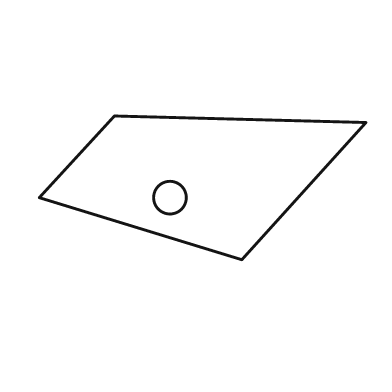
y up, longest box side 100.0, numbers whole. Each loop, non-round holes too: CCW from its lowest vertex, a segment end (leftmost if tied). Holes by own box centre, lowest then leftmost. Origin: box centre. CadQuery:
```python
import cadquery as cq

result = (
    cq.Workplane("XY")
    .moveTo(12.0, -22.0)
    .lineTo(50.0, 20.0)
    .lineTo(-27.0, 22.0)
    .lineTo(-50.0, -3.0)
    .close()
    .moveTo(-10.0, -3.0)
    .circle(5.0)
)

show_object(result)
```